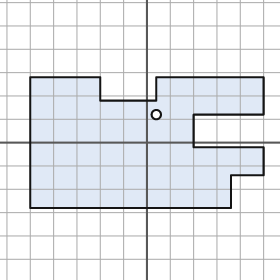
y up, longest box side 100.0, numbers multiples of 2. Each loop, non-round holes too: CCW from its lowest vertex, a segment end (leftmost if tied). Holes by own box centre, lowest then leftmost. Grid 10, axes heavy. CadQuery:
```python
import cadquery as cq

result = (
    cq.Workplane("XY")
    .moveTo(-50.0, -28.0)
    .lineTo(36.0, -28.0)
    .lineTo(36.0, -14.0)
    .lineTo(50.0, -14.0)
    .lineTo(50.0, -2.0)
    .lineTo(20.0, -2.0)
    .lineTo(20.0, 12.0)
    .lineTo(50.0, 12.0)
    .lineTo(50.0, 28.0)
    .lineTo(4.0, 28.0)
    .lineTo(4.0, 18.0)
    .lineTo(-20.0, 18.0)
    .lineTo(-20.0, 28.0)
    .lineTo(-50.0, 28.0)
    .close()
    .moveTo(4.0, 12.0)
    .circle(2.0)
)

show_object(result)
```